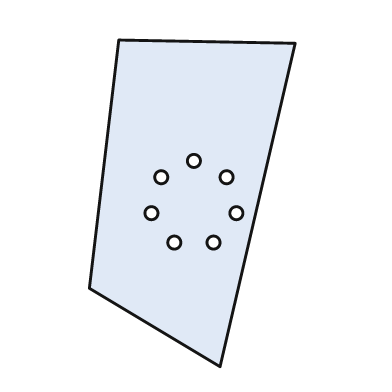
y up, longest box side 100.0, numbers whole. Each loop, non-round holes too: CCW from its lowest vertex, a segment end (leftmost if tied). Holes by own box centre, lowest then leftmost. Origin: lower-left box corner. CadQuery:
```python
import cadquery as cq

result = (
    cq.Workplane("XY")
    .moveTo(40.0, 0.0)
    .lineTo(63.0, 99.0)
    .lineTo(9.0, 100.0)
    .lineTo(0.0, 24.0)
    .close()
    .moveTo(26.0, 38.0)
    .circle(2.0)
    .moveTo(38.0, 38.0)
    .circle(2.0)
    .moveTo(19.0, 47.0)
    .circle(2.0)
    .moveTo(45.0, 47.0)
    .circle(2.0)
    .moveTo(22.0, 58.0)
    .circle(2.0)
    .moveTo(42.0, 58.0)
    .circle(2.0)
    .moveTo(32.0, 63.0)
    .circle(2.0)
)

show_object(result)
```